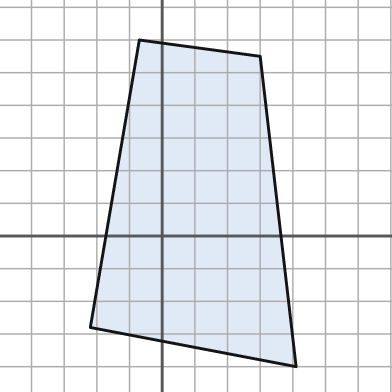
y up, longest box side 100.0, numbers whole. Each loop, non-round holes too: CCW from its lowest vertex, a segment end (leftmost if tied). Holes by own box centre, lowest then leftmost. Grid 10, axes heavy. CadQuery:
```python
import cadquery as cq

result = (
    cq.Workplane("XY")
    .moveTo(41.0, -40.0)
    .lineTo(30.0, 55.0)
    .lineTo(-7.0, 60.0)
    .lineTo(-22.0, -28.0)
    .close()
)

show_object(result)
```